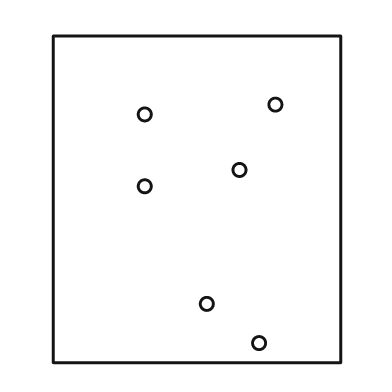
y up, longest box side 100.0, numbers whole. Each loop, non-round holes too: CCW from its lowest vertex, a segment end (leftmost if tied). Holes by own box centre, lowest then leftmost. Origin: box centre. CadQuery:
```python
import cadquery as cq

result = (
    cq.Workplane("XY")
    .moveTo(-44.0, -50.0)
    .lineTo(44.0, -50.0)
    .lineTo(44.0, 50.0)
    .lineTo(-44.0, 50.0)
    .close()
    .moveTo(19.0, -44.0)
    .circle(2.0)
    .moveTo(3.0, -32.0)
    .circle(2.0)
    .moveTo(-16.0, 4.0)
    .circle(2.0)
    .moveTo(13.0, 9.0)
    .circle(2.0)
    .moveTo(-16.0, 26.0)
    .circle(2.0)
    .moveTo(24.0, 29.0)
    .circle(2.0)
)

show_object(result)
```